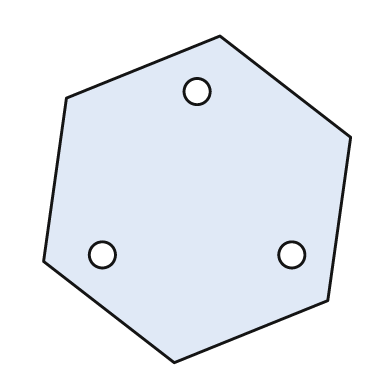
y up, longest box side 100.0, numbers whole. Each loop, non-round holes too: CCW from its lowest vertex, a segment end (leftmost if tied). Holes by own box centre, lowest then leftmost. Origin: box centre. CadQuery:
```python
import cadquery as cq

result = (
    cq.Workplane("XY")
    .moveTo(-7.0, -50.0)
    .lineTo(40.0, -31.0)
    .lineTo(47.0, 19.0)
    .lineTo(7.0, 50.0)
    .lineTo(-40.0, 31.0)
    .lineTo(-47.0, -19.0)
    .close()
    .moveTo(-29.0, -17.0)
    .circle(4.0)
    .moveTo(29.0, -17.0)
    .circle(4.0)
    .moveTo(0.0, 33.0)
    .circle(4.0)
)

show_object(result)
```